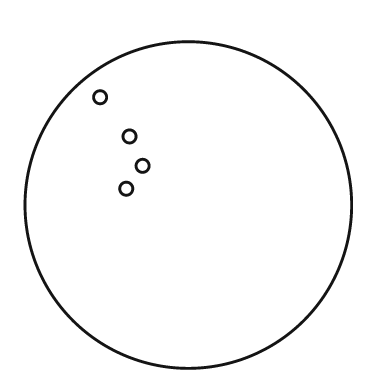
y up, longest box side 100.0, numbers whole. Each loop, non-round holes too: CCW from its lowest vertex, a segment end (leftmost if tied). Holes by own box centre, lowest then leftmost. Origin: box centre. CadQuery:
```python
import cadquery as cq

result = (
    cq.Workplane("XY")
    .moveTo(0.0, 0.0)
    .circle(50.0)
    .moveTo(-19.0, 5.0)
    .circle(2.0)
    .moveTo(-14.0, 12.0)
    .circle(2.0)
    .moveTo(-18.0, 21.0)
    .circle(2.0)
    .moveTo(-27.0, 33.0)
    .circle(2.0)
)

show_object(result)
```